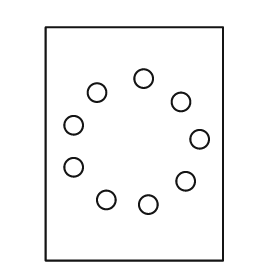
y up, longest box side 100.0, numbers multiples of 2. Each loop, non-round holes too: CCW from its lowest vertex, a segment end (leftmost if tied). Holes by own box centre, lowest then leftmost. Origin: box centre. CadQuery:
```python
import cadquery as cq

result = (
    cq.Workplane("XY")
    .moveTo(-38.0, -50.0)
    .lineTo(38.0, -50.0)
    .lineTo(38.0, 50.0)
    .lineTo(-38.0, 50.0)
    .close()
    .moveTo(6.0, -26.0)
    .circle(4.0)
    .moveTo(-12.0, -24.0)
    .circle(4.0)
    .moveTo(22.0, -16.0)
    .circle(4.0)
    .moveTo(-26.0, -10.0)
    .circle(4.0)
    .moveTo(28.0, 2.0)
    .circle(4.0)
    .moveTo(-26.0, 8.0)
    .circle(4.0)
    .moveTo(20.0, 18.0)
    .circle(4.0)
    .moveTo(-16.0, 22.0)
    .circle(4.0)
    .moveTo(4.0, 28.0)
    .circle(4.0)
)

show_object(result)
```